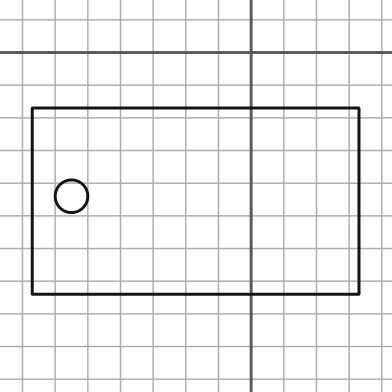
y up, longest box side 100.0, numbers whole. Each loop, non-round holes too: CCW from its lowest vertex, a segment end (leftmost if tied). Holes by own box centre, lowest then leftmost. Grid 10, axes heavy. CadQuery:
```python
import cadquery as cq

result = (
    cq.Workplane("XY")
    .moveTo(-67.0, -74.0)
    .lineTo(33.0, -74.0)
    .lineTo(33.0, -17.0)
    .lineTo(-67.0, -17.0)
    .close()
    .moveTo(-55.0, -44.0)
    .circle(5.0)
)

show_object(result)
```